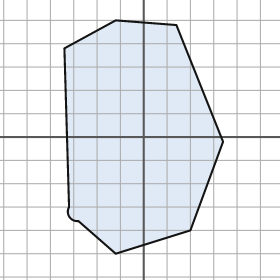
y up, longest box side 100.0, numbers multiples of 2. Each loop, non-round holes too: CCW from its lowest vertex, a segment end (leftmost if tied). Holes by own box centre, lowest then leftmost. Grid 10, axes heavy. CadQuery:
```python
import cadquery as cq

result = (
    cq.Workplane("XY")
    .moveTo(-12.0, -50.0)
    .lineTo(20.0, -40.0)
    .lineTo(34.0, -2.0)
    .lineTo(14.0, 48.0)
    .lineTo(-12.0, 50.0)
    .lineTo(-34.0, 38.0)
    .lineTo(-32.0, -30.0)
    .threePointArc((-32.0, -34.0), (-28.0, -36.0))
    .close()
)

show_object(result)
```